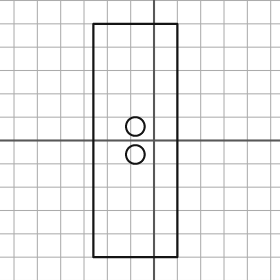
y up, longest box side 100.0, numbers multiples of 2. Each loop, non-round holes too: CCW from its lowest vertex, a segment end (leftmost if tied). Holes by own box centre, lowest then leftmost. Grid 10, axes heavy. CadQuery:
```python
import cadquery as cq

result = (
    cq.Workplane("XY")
    .moveTo(-26.0, -50.0)
    .lineTo(10.0, -50.0)
    .lineTo(10.0, 50.0)
    .lineTo(-26.0, 50.0)
    .close()
    .moveTo(-8.0, -6.0)
    .circle(4.0)
    .moveTo(-8.0, 6.0)
    .circle(4.0)
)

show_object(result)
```